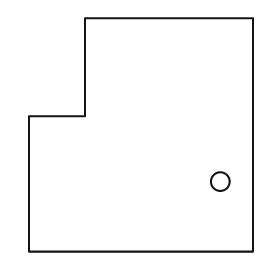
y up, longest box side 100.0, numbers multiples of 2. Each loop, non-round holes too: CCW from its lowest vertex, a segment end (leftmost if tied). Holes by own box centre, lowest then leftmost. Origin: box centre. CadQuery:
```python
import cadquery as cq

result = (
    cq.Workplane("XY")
    .moveTo(-48.0, -50.0)
    .lineTo(48.0, -50.0)
    .lineTo(48.0, 50.0)
    .lineTo(-24.0, 50.0)
    .lineTo(-24.0, 8.0)
    .lineTo(-48.0, 8.0)
    .close()
    .moveTo(34.0, -20.0)
    .circle(4.0)
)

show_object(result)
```